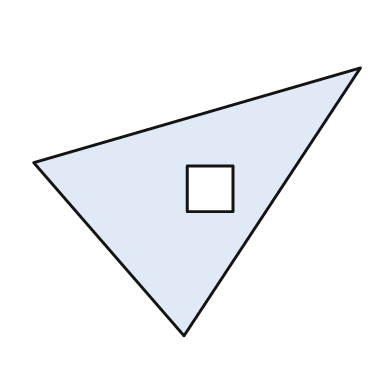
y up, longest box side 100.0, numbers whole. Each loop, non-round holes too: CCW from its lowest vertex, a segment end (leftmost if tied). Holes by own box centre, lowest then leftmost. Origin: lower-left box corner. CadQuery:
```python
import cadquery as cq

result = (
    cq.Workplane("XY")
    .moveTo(46.0, 0.0)
    .lineTo(100.0, 82.0)
    .lineTo(0.0, 53.0)
    .close()
    .moveTo(47.0, 38.0)
    .lineTo(61.0, 38.0)
    .lineTo(61.0, 52.0)
    .lineTo(47.0, 52.0)
    .close()
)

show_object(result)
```